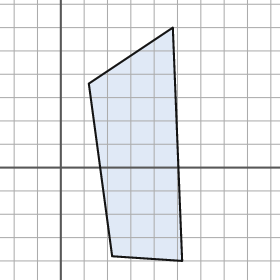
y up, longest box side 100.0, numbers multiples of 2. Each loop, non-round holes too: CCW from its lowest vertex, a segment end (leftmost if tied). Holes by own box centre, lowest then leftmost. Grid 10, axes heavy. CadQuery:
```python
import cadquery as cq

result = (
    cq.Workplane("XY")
    .moveTo(52.0, -40.0)
    .lineTo(48.0, 60.0)
    .lineTo(12.0, 36.0)
    .lineTo(22.0, -38.0)
    .close()
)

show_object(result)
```